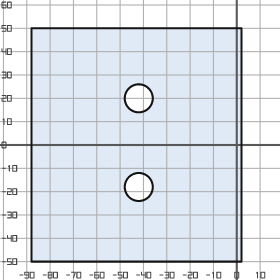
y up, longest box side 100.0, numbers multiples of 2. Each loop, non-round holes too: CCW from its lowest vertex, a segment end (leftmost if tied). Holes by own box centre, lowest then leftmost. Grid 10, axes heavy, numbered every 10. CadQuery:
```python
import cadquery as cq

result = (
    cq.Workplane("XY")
    .moveTo(-88.0, -50.0)
    .lineTo(2.0, -50.0)
    .lineTo(2.0, 50.0)
    .lineTo(-88.0, 50.0)
    .close()
    .moveTo(-42.0, -18.0)
    .circle(6.0)
    .moveTo(-42.0, 20.0)
    .circle(6.0)
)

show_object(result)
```